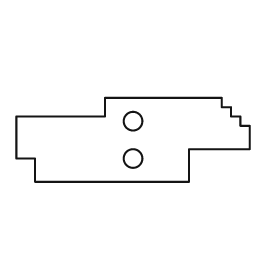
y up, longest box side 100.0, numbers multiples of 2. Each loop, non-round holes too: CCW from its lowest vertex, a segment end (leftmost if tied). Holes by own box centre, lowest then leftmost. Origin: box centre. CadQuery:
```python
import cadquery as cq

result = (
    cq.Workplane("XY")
    .moveTo(-42.0, -18.0)
    .lineTo(24.0, -18.0)
    .lineTo(24.0, -4.0)
    .lineTo(50.0, -4.0)
    .lineTo(50.0, 6.0)
    .lineTo(46.0, 6.0)
    .lineTo(46.0, 10.0)
    .lineTo(42.0, 10.0)
    .lineTo(42.0, 14.0)
    .lineTo(38.0, 14.0)
    .lineTo(38.0, 18.0)
    .lineTo(-12.0, 18.0)
    .lineTo(-12.0, 10.0)
    .lineTo(-50.0, 10.0)
    .lineTo(-50.0, -8.0)
    .lineTo(-42.0, -8.0)
    .close()
    .moveTo(0.0, -8.0)
    .circle(4.0)
    .moveTo(0.0, 8.0)
    .circle(4.0)
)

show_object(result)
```